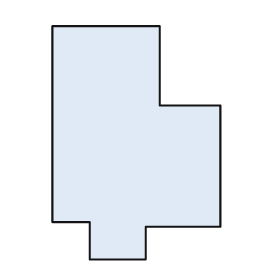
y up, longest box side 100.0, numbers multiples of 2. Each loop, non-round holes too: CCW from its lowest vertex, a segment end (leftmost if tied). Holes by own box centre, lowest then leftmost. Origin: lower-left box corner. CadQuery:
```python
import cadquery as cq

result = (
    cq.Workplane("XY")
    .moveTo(16.0, 0.0)
    .lineTo(40.0, 0.0)
    .lineTo(40.0, 14.0)
    .lineTo(72.0, 14.0)
    .lineTo(72.0, 66.0)
    .lineTo(46.0, 66.0)
    .lineTo(46.0, 100.0)
    .lineTo(0.0, 100.0)
    .lineTo(0.0, 16.0)
    .lineTo(16.0, 16.0)
    .close()
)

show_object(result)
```